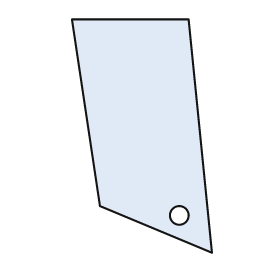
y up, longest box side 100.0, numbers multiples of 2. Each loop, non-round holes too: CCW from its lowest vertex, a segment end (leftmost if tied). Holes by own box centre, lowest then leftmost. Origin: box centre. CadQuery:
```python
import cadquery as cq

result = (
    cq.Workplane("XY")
    .moveTo(30.0, -50.0)
    .lineTo(20.0, 50.0)
    .lineTo(-30.0, 50.0)
    .lineTo(-18.0, -30.0)
    .close()
    .moveTo(16.0, -34.0)
    .circle(4.0)
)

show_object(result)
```